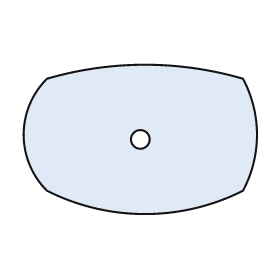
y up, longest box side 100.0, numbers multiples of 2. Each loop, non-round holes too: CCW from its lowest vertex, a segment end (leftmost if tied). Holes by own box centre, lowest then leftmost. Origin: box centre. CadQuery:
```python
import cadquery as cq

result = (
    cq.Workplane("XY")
    .moveTo(-40.0, -22.0)
    .threePointArc((2.0, -32.0), (44.0, -22.0))
    .threePointArc((50.0, 2.0), (44.0, 26.0))
    .threePointArc((2.0, 32.0), (-40.0, 26.0))
    .threePointArc((-50.0, 2.0), (-40.0, -22.0))
    .close()
    .moveTo(0.0, 0.0)
    .circle(4.0)
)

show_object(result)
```